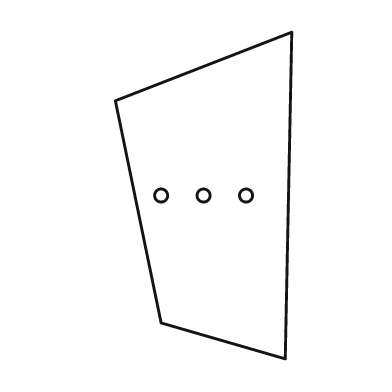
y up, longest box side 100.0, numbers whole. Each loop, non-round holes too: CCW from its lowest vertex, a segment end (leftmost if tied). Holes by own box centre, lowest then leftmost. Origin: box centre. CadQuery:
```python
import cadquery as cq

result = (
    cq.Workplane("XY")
    .moveTo(25.0, -50.0)
    .lineTo(27.0, 50.0)
    .lineTo(-27.0, 29.0)
    .lineTo(-13.0, -39.0)
    .close()
    .moveTo(-13.0, 0.0)
    .circle(2.0)
    .moveTo(0.0, 0.0)
    .circle(2.0)
    .moveTo(13.0, 0.0)
    .circle(2.0)
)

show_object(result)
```